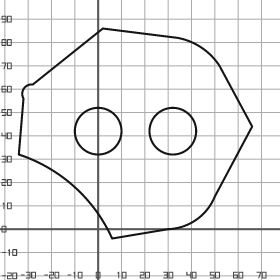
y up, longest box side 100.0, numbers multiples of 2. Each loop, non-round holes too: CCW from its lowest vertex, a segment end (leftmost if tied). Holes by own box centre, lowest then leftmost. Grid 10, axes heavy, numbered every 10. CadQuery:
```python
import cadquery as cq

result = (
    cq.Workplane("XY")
    .moveTo(6.0, -4.0)
    .lineTo(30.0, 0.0)
    .threePointArc((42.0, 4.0), (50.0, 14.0))
    .lineTo(66.0, 44.0)
    .lineTo(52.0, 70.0)
    .threePointArc((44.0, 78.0), (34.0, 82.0))
    .lineTo(2.0, 86.0)
    .lineTo(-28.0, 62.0)
    .threePointArc((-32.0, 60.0), (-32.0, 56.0))
    .lineTo(-34.0, 32.0)
    .threePointArc((-10.0, 18.0), (6.0, -4.0))
    .close()
    .moveTo(0.0, 42.0)
    .circle(10.0)
    .moveTo(32.0, 42.0)
    .circle(10.0)
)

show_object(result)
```